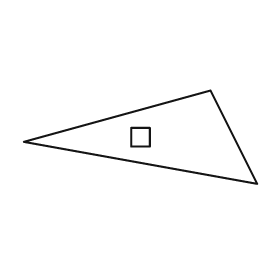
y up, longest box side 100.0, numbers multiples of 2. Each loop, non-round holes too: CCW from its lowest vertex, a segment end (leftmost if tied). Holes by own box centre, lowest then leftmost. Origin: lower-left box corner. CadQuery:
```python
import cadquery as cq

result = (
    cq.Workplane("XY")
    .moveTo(100.0, 0.0)
    .lineTo(80.0, 40.0)
    .lineTo(0.0, 18.0)
    .close()
    .moveTo(46.0, 16.0)
    .lineTo(54.0, 16.0)
    .lineTo(54.0, 24.0)
    .lineTo(46.0, 24.0)
    .close()
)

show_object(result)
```